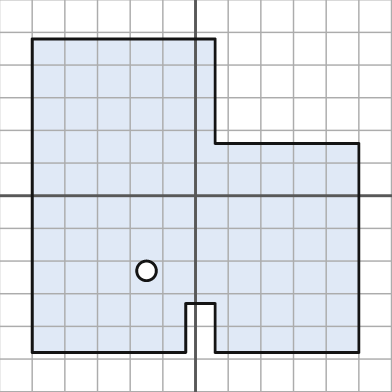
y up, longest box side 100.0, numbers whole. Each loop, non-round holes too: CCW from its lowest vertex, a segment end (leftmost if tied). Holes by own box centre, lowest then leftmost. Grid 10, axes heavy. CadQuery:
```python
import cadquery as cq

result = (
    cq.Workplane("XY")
    .moveTo(-50.0, -48.0)
    .lineTo(-3.0, -48.0)
    .lineTo(-3.0, -33.0)
    .lineTo(6.0, -33.0)
    .lineTo(6.0, -48.0)
    .lineTo(50.0, -48.0)
    .lineTo(50.0, 16.0)
    .lineTo(6.0, 16.0)
    .lineTo(6.0, 48.0)
    .lineTo(-50.0, 48.0)
    .close()
    .moveTo(-15.0, -23.0)
    .circle(3.0)
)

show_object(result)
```